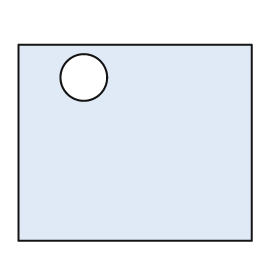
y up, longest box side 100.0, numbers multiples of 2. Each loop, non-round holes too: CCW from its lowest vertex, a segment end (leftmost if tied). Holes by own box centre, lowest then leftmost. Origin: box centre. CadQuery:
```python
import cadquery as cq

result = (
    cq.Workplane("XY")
    .moveTo(-50.0, -42.0)
    .lineTo(50.0, -42.0)
    .lineTo(50.0, 42.0)
    .lineTo(-50.0, 42.0)
    .close()
    .moveTo(-22.0, 28.0)
    .circle(10.0)
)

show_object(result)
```